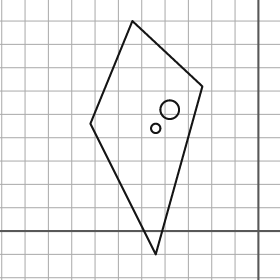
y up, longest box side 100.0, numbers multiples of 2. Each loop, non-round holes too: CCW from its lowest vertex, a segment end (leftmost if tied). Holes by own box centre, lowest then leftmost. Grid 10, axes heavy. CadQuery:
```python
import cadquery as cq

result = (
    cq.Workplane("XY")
    .moveTo(-44.0, -10.0)
    .lineTo(-24.0, 62.0)
    .lineTo(-54.0, 90.0)
    .lineTo(-72.0, 46.0)
    .close()
    .moveTo(-44.0, 44.0)
    .circle(2.0)
    .moveTo(-38.0, 52.0)
    .circle(4.0)
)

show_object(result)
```